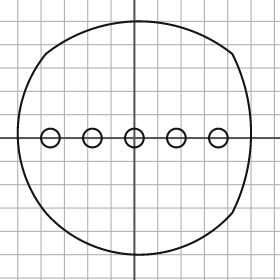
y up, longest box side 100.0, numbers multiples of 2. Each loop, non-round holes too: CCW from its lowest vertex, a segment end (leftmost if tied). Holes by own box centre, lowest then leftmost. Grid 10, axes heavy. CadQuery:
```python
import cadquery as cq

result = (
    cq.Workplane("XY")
    .moveTo(-38.0, -32.0)
    .threePointArc((2.0, -50.0), (42.0, -32.0))
    .threePointArc((50.0, 2.0), (42.0, 36.0))
    .threePointArc((2.0, 50.0), (-38.0, 36.0))
    .threePointArc((-50.0, 2.0), (-38.0, -32.0))
    .close()
    .moveTo(-36.0, 0.0)
    .circle(4.0)
    .moveTo(-18.0, 0.0)
    .circle(4.0)
    .moveTo(0.0, 0.0)
    .circle(4.0)
    .moveTo(18.0, 0.0)
    .circle(4.0)
    .moveTo(36.0, 0.0)
    .circle(4.0)
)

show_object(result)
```